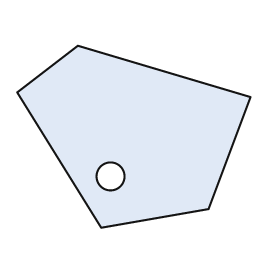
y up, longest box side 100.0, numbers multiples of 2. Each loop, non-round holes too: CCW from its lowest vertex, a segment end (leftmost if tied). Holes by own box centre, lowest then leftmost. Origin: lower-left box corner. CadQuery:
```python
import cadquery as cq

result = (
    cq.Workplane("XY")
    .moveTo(36.0, 0.0)
    .lineTo(82.0, 8.0)
    .lineTo(100.0, 56.0)
    .lineTo(26.0, 78.0)
    .lineTo(0.0, 58.0)
    .close()
    .moveTo(40.0, 22.0)
    .circle(6.0)
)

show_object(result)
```